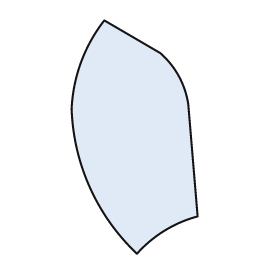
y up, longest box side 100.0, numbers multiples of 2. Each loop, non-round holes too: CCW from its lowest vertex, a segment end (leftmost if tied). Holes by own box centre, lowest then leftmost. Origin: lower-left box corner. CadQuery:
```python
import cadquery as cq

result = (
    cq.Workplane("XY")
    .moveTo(28.0, 0.0)
    .threePointArc((40.0, 10.0), (54.0, 16.0))
    .lineTo(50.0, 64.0)
    .threePointArc((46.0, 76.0), (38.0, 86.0))
    .lineTo(14.0, 100.0)
    .threePointArc((4.0, 82.0), (0.0, 62.0))
    .threePointArc((8.0, 28.0), (28.0, 0.0))
    .close()
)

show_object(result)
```